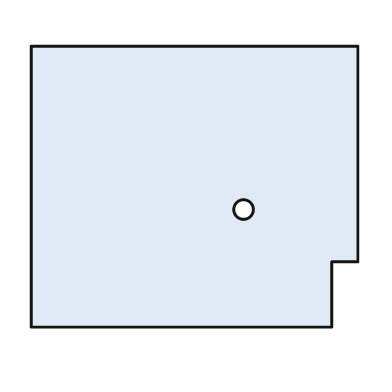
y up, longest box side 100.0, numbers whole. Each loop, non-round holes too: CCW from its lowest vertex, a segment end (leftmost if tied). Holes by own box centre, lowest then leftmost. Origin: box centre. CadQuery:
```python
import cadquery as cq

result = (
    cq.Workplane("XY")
    .moveTo(-50.0, -43.0)
    .lineTo(42.0, -43.0)
    .lineTo(42.0, -23.0)
    .lineTo(50.0, -23.0)
    .lineTo(50.0, 43.0)
    .lineTo(-50.0, 43.0)
    .close()
    .moveTo(15.0, -7.0)
    .circle(3.0)
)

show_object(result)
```